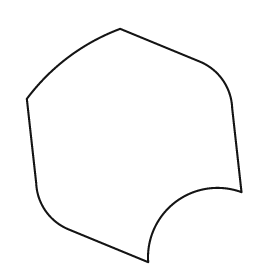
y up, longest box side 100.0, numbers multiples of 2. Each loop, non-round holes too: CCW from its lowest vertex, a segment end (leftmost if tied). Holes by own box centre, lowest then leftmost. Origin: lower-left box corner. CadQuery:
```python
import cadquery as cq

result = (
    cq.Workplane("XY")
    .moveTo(52.0, 0.0)
    .threePointArc((64.0, 26.0), (92.0, 30.0))
    .lineTo(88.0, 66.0)
    .threePointArc((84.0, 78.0), (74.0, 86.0))
    .lineTo(40.0, 100.0)
    .threePointArc((18.0, 88.0), (0.0, 70.0))
    .lineTo(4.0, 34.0)
    .threePointArc((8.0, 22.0), (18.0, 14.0))
    .close()
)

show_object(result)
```